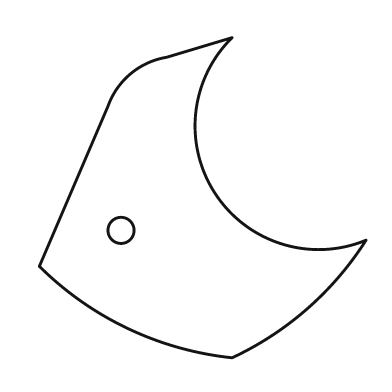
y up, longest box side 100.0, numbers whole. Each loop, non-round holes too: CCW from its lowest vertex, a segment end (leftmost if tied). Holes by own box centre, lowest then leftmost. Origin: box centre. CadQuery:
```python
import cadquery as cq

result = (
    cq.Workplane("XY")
    .moveTo(9.0, -49.0)
    .threePointArc((32.0, -34.0), (50.0, -13.0))
    .threePointArc((4.0, 1.0), (9.0, 49.0))
    .lineTo(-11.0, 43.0)
    .threePointArc((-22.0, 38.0), (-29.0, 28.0))
    .lineTo(-50.0, -21.0)
    .threePointArc((-23.0, -40.0), (9.0, -49.0))
    .close()
    .moveTo(-25.0, -10.0)
    .circle(4.0)
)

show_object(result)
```